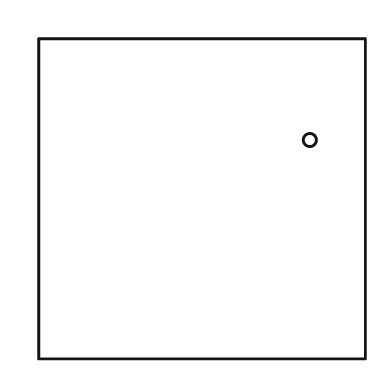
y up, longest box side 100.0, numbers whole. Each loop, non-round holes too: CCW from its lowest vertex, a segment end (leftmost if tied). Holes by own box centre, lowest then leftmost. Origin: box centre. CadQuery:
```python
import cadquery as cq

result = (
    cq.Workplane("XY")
    .moveTo(-50.0, -49.0)
    .lineTo(50.0, -49.0)
    .lineTo(50.0, 49.0)
    .lineTo(-50.0, 49.0)
    .close()
    .moveTo(33.0, 18.0)
    .circle(2.0)
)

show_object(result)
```